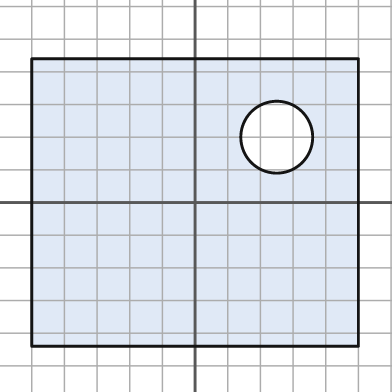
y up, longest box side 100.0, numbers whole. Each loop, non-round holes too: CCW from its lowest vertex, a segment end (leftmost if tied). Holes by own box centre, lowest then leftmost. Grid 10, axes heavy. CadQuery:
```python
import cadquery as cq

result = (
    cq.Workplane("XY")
    .moveTo(-50.0, -44.0)
    .lineTo(50.0, -44.0)
    .lineTo(50.0, 44.0)
    .lineTo(-50.0, 44.0)
    .close()
    .moveTo(25.0, 20.0)
    .circle(11.0)
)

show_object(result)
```